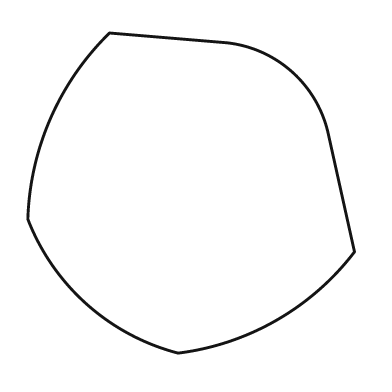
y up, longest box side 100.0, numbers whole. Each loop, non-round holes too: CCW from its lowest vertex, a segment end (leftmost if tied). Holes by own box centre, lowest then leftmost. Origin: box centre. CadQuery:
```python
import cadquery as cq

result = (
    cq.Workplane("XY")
    .moveTo(-4.0, -49.0)
    .threePointArc((26.0, -39.0), (50.0, -18.0))
    .lineTo(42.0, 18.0)
    .threePointArc((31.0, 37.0), (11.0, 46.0))
    .lineTo(-25.0, 49.0)
    .threePointArc((-43.0, 23.0), (-50.0, -8.0))
    .threePointArc((-32.0, -34.0), (-4.0, -49.0))
    .close()
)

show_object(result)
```